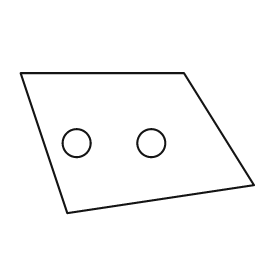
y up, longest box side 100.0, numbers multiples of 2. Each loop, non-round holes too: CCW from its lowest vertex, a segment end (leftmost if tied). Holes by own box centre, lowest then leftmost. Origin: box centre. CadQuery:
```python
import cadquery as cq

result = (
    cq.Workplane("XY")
    .moveTo(-30.0, -30.0)
    .lineTo(50.0, -18.0)
    .lineTo(20.0, 30.0)
    .lineTo(-50.0, 30.0)
    .close()
    .moveTo(-26.0, 0.0)
    .circle(6.0)
    .moveTo(6.0, 0.0)
    .circle(6.0)
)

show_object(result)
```